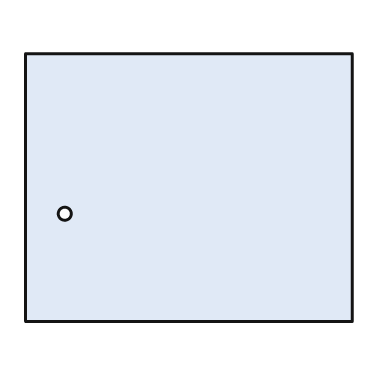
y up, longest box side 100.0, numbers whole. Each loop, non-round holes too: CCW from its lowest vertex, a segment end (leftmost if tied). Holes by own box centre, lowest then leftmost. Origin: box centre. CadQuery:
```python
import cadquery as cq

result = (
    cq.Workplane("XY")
    .moveTo(-50.0, -41.0)
    .lineTo(50.0, -41.0)
    .lineTo(50.0, 41.0)
    .lineTo(-50.0, 41.0)
    .close()
    .moveTo(-38.0, -8.0)
    .circle(2.0)
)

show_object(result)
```